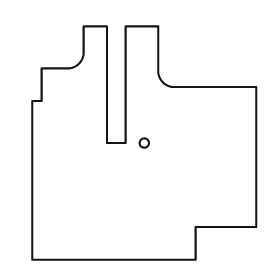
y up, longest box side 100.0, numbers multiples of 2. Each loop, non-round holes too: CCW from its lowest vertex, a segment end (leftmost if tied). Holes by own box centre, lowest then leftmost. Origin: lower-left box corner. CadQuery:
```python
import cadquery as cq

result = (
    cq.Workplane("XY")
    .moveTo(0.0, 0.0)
    .lineTo(70.0, 0.0)
    .lineTo(70.0, 14.0)
    .lineTo(96.0, 14.0)
    .lineTo(96.0, 74.0)
    .lineTo(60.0, 74.0)
    .threePointArc((56.0, 76.0), (54.0, 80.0))
    .lineTo(54.0, 100.0)
    .lineTo(40.0, 100.0)
    .lineTo(40.0, 50.0)
    .lineTo(32.0, 50.0)
    .lineTo(32.0, 100.0)
    .lineTo(22.0, 100.0)
    .lineTo(22.0, 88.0)
    .threePointArc((20.0, 84.0), (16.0, 82.0))
    .lineTo(4.0, 82.0)
    .lineTo(4.0, 68.0)
    .lineTo(0.0, 68.0)
    .close()
    .moveTo(48.0, 50.0)
    .circle(2.0)
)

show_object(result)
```